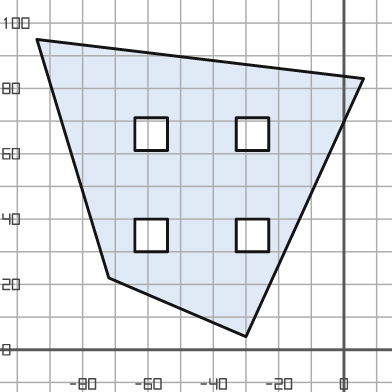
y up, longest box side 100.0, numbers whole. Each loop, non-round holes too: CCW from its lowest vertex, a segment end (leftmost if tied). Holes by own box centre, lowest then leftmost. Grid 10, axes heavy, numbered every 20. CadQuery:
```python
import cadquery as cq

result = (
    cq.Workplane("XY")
    .moveTo(-30.0, 4.0)
    .lineTo(6.0, 83.0)
    .lineTo(-94.0, 95.0)
    .lineTo(-72.0, 22.0)
    .close()
    .moveTo(-64.0, 30.0)
    .lineTo(-54.0, 30.0)
    .lineTo(-54.0, 40.0)
    .lineTo(-64.0, 40.0)
    .close()
    .moveTo(-33.0, 30.0)
    .lineTo(-23.0, 30.0)
    .lineTo(-23.0, 40.0)
    .lineTo(-33.0, 40.0)
    .close()
    .moveTo(-64.0, 61.0)
    .lineTo(-54.0, 61.0)
    .lineTo(-54.0, 71.0)
    .lineTo(-64.0, 71.0)
    .close()
    .moveTo(-33.0, 61.0)
    .lineTo(-23.0, 61.0)
    .lineTo(-23.0, 71.0)
    .lineTo(-33.0, 71.0)
    .close()
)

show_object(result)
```